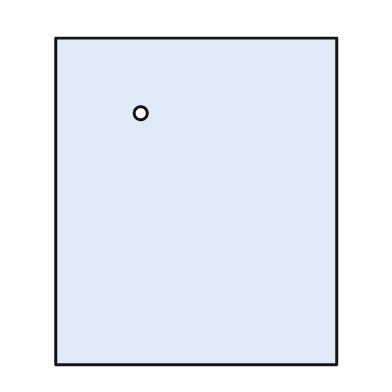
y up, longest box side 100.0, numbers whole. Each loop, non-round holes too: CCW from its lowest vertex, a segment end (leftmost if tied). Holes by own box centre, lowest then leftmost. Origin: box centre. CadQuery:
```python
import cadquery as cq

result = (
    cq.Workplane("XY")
    .moveTo(-43.0, -50.0)
    .lineTo(43.0, -50.0)
    .lineTo(43.0, 50.0)
    .lineTo(-43.0, 50.0)
    .close()
    .moveTo(-17.0, 27.0)
    .circle(2.0)
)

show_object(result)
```